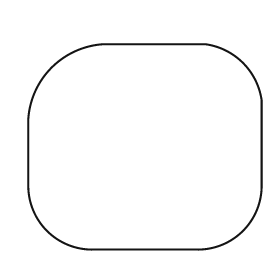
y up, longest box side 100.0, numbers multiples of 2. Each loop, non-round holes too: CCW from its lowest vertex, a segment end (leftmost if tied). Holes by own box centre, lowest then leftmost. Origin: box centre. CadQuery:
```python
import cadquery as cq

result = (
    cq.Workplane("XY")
    .moveTo(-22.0, -44.0)
    .lineTo(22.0, -44.0)
    .threePointArc((42.0, -36.0), (50.0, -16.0))
    .lineTo(50.0, 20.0)
    .threePointArc((42.0, 36.0), (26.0, 44.0))
    .lineTo(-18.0, 44.0)
    .threePointArc((-40.0, 34.0), (-50.0, 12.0))
    .lineTo(-50.0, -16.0)
    .threePointArc((-42.0, -36.0), (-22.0, -44.0))
    .close()
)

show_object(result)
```